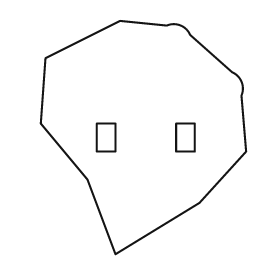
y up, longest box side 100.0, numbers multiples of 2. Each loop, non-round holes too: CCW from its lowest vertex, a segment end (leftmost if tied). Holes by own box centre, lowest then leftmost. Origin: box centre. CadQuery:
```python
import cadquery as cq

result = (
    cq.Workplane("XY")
    .moveTo(-12.0, -50.0)
    .lineTo(24.0, -28.0)
    .lineTo(44.0, -6.0)
    .lineTo(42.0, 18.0)
    .threePointArc((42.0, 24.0), (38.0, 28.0))
    .lineTo(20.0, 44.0)
    .threePointArc((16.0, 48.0), (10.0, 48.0))
    .lineTo(-10.0, 50.0)
    .lineTo(-42.0, 34.0)
    .lineTo(-44.0, 6.0)
    .lineTo(-24.0, -18.0)
    .close()
    .moveTo(-20.0, -6.0)
    .lineTo(-12.0, -6.0)
    .lineTo(-12.0, 6.0)
    .lineTo(-20.0, 6.0)
    .close()
    .moveTo(14.0, -6.0)
    .lineTo(22.0, -6.0)
    .lineTo(22.0, 6.0)
    .lineTo(14.0, 6.0)
    .close()
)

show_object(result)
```